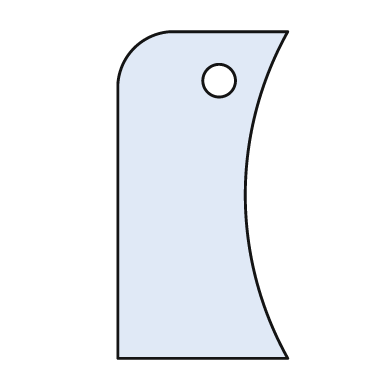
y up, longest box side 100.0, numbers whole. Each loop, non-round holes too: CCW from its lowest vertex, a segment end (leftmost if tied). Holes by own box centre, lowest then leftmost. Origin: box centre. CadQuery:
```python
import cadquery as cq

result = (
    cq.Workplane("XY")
    .moveTo(-26.0, -50.0)
    .lineTo(26.0, -50.0)
    .threePointArc((13.0, 0.0), (26.0, 50.0))
    .lineTo(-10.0, 50.0)
    .threePointArc((-21.0, 45.0), (-26.0, 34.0))
    .close()
    .moveTo(5.0, 35.0)
    .circle(5.0)
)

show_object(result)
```